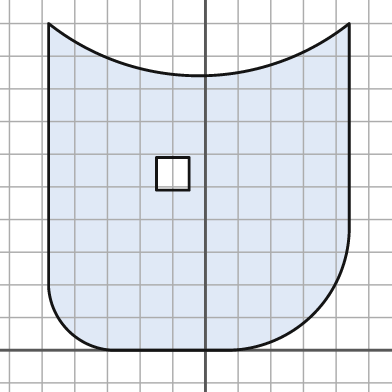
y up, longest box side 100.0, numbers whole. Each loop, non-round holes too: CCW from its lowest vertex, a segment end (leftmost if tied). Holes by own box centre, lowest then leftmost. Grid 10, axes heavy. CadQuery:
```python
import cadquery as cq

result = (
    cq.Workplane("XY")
    .moveTo(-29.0, 0.0)
    .lineTo(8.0, 0.0)
    .threePointArc((33.0, 11.0), (44.0, 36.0))
    .lineTo(44.0, 100.0)
    .threePointArc((-2.0, 84.0), (-48.0, 100.0))
    .lineTo(-48.0, 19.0)
    .threePointArc((-42.0, 6.0), (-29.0, 0.0))
    .close()
    .moveTo(-15.0, 49.0)
    .lineTo(-5.0, 49.0)
    .lineTo(-5.0, 59.0)
    .lineTo(-15.0, 59.0)
    .close()
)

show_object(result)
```